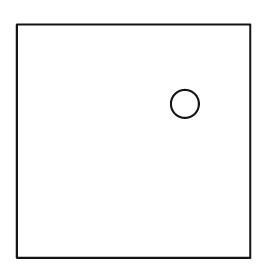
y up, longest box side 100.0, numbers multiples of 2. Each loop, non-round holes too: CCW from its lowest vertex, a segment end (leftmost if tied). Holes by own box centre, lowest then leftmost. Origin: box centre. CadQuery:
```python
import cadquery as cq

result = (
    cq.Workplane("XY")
    .moveTo(-50.0, -50.0)
    .lineTo(50.0, -50.0)
    .lineTo(50.0, 50.0)
    .lineTo(-50.0, 50.0)
    .close()
    .moveTo(22.0, 16.0)
    .circle(6.0)
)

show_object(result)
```